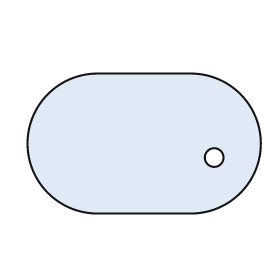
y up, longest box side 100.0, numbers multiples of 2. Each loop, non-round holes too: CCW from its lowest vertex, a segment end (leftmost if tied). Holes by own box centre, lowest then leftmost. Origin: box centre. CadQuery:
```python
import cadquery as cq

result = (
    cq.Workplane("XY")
    .moveTo(-20.0, -30.0)
    .lineTo(20.0, -30.0)
    .threePointArc((50.0, 0.0), (20.0, 30.0))
    .lineTo(-20.0, 30.0)
    .threePointArc((-50.0, 0.0), (-20.0, -30.0))
    .close()
    .moveTo(30.0, -6.0)
    .circle(4.0)
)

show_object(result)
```